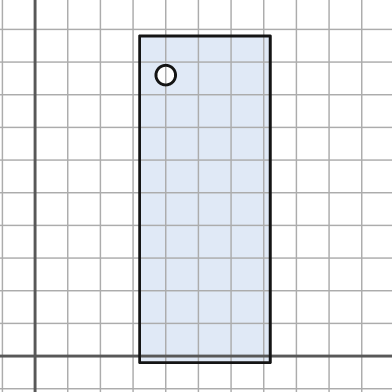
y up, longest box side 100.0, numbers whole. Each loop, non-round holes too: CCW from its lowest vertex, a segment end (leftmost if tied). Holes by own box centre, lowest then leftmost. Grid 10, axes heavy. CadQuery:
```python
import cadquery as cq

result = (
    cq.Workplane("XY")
    .moveTo(32.0, -2.0)
    .lineTo(72.0, -2.0)
    .lineTo(72.0, 98.0)
    .lineTo(32.0, 98.0)
    .close()
    .moveTo(40.0, 86.0)
    .circle(3.0)
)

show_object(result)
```